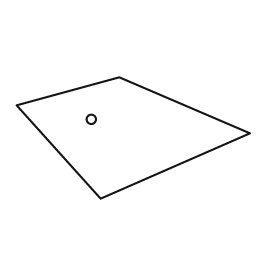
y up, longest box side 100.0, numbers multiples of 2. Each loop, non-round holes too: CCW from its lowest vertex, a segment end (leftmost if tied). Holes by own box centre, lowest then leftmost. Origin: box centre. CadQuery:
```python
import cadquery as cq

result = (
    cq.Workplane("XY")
    .moveTo(-14.0, -26.0)
    .lineTo(50.0, 2.0)
    .lineTo(-6.0, 26.0)
    .lineTo(-50.0, 14.0)
    .close()
    .moveTo(-18.0, 8.0)
    .circle(2.0)
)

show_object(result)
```